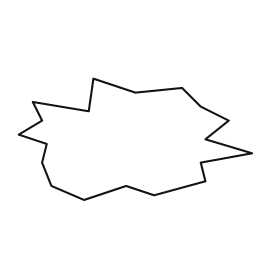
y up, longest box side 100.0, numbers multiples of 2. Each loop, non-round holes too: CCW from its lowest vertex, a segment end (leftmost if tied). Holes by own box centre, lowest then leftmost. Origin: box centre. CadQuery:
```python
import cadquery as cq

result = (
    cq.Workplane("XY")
    .moveTo(-22.0, -26.0)
    .lineTo(-4.0, -20.0)
    .lineTo(8.0, -24.0)
    .lineTo(30.0, -18.0)
    .lineTo(28.0, -10.0)
    .lineTo(50.0, -6.0)
    .lineTo(30.0, 0.0)
    .lineTo(40.0, 8.0)
    .lineTo(28.0, 14.0)
    .lineTo(20.0, 22.0)
    .lineTo(0.0, 20.0)
    .lineTo(-18.0, 26.0)
    .lineTo(-20.0, 12.0)
    .lineTo(-44.0, 16.0)
    .lineTo(-40.0, 8.0)
    .lineTo(-50.0, 2.0)
    .lineTo(-38.0, -2.0)
    .lineTo(-40.0, -10.0)
    .lineTo(-36.0, -20.0)
    .close()
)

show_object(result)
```